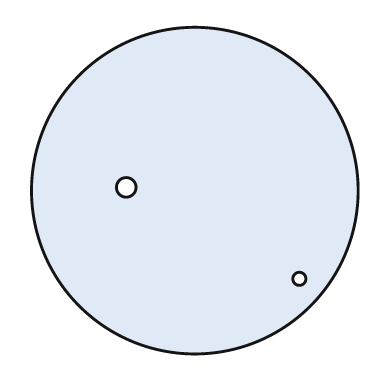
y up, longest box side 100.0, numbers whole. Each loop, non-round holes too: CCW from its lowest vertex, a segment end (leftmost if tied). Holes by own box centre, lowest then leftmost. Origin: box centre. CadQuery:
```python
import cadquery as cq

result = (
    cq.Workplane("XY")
    .moveTo(0.0, 0.0)
    .circle(50.0)
    .moveTo(32.0, -27.0)
    .circle(2.0)
    .moveTo(-21.0, 1.0)
    .circle(3.0)
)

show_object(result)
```